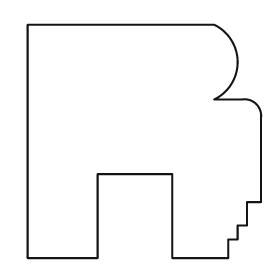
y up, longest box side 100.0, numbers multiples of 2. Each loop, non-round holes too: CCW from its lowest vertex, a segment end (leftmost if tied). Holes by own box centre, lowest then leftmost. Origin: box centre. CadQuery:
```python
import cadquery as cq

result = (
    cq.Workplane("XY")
    .moveTo(-50.0, -50.0)
    .lineTo(-20.0, -50.0)
    .lineTo(-20.0, -14.0)
    .lineTo(12.0, -14.0)
    .lineTo(12.0, -50.0)
    .lineTo(36.0, -50.0)
    .lineTo(36.0, -42.0)
    .lineTo(40.0, -42.0)
    .lineTo(40.0, -36.0)
    .lineTo(44.0, -36.0)
    .lineTo(44.0, -26.0)
    .lineTo(50.0, -26.0)
    .lineTo(50.0, 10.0)
    .threePointArc((48.0, 16.0), (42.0, 18.0))
    .lineTo(30.0, 18.0)
    .threePointArc((40.0, 34.0), (30.0, 50.0))
    .lineTo(-50.0, 50.0)
    .close()
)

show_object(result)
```